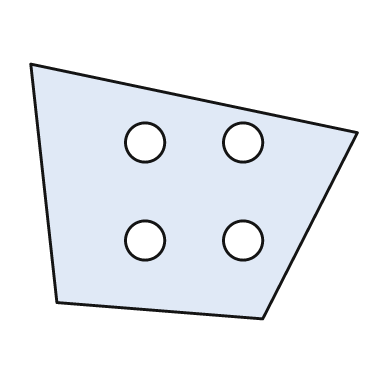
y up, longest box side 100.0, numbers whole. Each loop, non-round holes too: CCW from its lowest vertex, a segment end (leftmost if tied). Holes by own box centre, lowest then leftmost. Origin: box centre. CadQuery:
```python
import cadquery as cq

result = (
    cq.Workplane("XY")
    .moveTo(21.0, -39.0)
    .lineTo(50.0, 18.0)
    .lineTo(-50.0, 39.0)
    .lineTo(-42.0, -34.0)
    .close()
    .moveTo(-15.0, -15.0)
    .circle(6.0)
    .moveTo(15.0, -15.0)
    .circle(6.0)
    .moveTo(-15.0, 15.0)
    .circle(6.0)
    .moveTo(15.0, 15.0)
    .circle(6.0)
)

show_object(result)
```